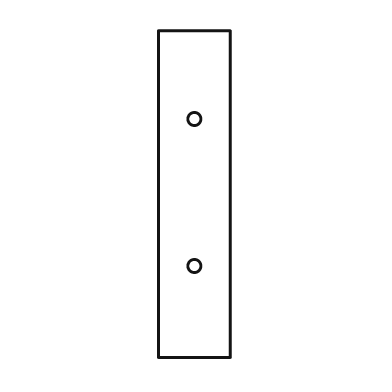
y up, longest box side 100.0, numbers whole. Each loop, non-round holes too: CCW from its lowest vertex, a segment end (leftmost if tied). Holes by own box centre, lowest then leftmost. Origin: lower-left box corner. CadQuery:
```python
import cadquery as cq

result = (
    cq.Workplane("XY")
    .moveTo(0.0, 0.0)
    .lineTo(22.0, 0.0)
    .lineTo(22.0, 100.0)
    .lineTo(0.0, 100.0)
    .close()
    .moveTo(11.0, 28.0)
    .circle(2.0)
    .moveTo(11.0, 73.0)
    .circle(2.0)
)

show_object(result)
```